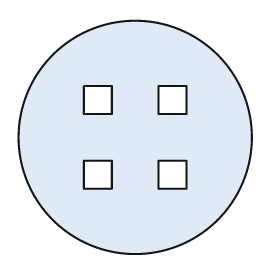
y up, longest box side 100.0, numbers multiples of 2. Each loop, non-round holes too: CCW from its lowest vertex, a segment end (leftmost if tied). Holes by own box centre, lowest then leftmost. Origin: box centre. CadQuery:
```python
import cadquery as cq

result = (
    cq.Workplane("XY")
    .moveTo(0.0, 0.0)
    .circle(50.0)
    .moveTo(-22.0, -22.0)
    .lineTo(-10.0, -22.0)
    .lineTo(-10.0, -10.0)
    .lineTo(-22.0, -10.0)
    .close()
    .moveTo(10.0, -22.0)
    .lineTo(22.0, -22.0)
    .lineTo(22.0, -10.0)
    .lineTo(10.0, -10.0)
    .close()
    .moveTo(-22.0, 10.0)
    .lineTo(-10.0, 10.0)
    .lineTo(-10.0, 22.0)
    .lineTo(-22.0, 22.0)
    .close()
    .moveTo(10.0, 10.0)
    .lineTo(22.0, 10.0)
    .lineTo(22.0, 22.0)
    .lineTo(10.0, 22.0)
    .close()
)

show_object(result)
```